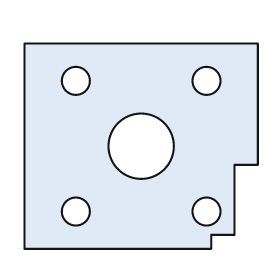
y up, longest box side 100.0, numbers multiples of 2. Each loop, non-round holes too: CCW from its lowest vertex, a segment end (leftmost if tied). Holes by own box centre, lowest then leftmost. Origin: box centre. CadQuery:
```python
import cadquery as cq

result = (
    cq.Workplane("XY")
    .moveTo(-50.0, -44.0)
    .lineTo(30.0, -44.0)
    .lineTo(30.0, -38.0)
    .lineTo(40.0, -38.0)
    .lineTo(40.0, -8.0)
    .lineTo(50.0, -8.0)
    .lineTo(50.0, 44.0)
    .lineTo(-50.0, 44.0)
    .close()
    .moveTo(-28.0, -28.0)
    .circle(6.0)
    .moveTo(28.0, -28.0)
    .circle(6.0)
    .moveTo(0.0, 0.0)
    .circle(14.0)
    .moveTo(-28.0, 28.0)
    .circle(6.0)
    .moveTo(28.0, 28.0)
    .circle(6.0)
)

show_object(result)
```